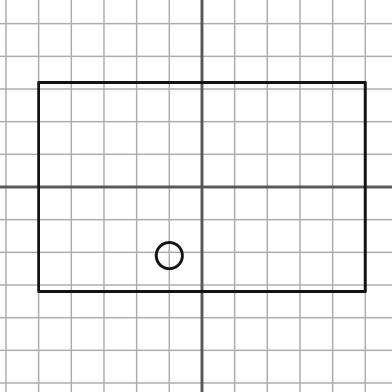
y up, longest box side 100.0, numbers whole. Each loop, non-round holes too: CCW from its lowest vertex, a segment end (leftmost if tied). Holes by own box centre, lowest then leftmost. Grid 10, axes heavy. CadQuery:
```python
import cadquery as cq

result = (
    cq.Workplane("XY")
    .moveTo(-50.0, -32.0)
    .lineTo(50.0, -32.0)
    .lineTo(50.0, 32.0)
    .lineTo(-50.0, 32.0)
    .close()
    .moveTo(-10.0, -21.0)
    .circle(4.0)
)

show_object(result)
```